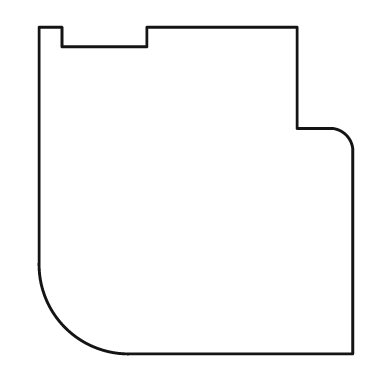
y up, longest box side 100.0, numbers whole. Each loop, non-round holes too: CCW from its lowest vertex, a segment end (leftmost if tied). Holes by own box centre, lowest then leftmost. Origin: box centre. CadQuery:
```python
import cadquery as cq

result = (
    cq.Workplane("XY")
    .moveTo(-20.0, -50.0)
    .lineTo(48.0, -50.0)
    .lineTo(48.0, 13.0)
    .threePointArc((46.0, 17.0), (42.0, 19.0))
    .lineTo(31.0, 19.0)
    .lineTo(31.0, 50.0)
    .lineTo(-15.0, 50.0)
    .lineTo(-15.0, 44.0)
    .lineTo(-41.0, 44.0)
    .lineTo(-41.0, 50.0)
    .lineTo(-48.0, 50.0)
    .lineTo(-48.0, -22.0)
    .threePointArc((-40.0, -42.0), (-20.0, -50.0))
    .close()
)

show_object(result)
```